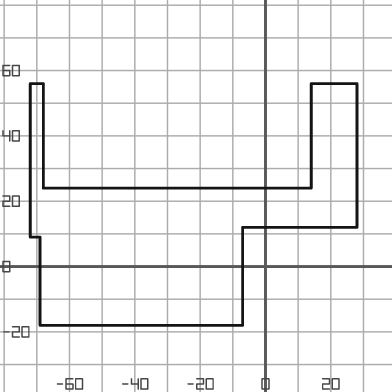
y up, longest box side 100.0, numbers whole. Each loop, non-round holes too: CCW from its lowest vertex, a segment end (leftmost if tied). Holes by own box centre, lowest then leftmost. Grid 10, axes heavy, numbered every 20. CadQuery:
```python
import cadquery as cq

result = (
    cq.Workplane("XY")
    .moveTo(-69.0, -18.0)
    .lineTo(-7.0, -18.0)
    .lineTo(-7.0, 12.0)
    .lineTo(28.0, 12.0)
    .lineTo(28.0, 56.0)
    .lineTo(14.0, 56.0)
    .lineTo(14.0, 24.0)
    .lineTo(-68.0, 24.0)
    .lineTo(-68.0, 56.0)
    .lineTo(-72.0, 56.0)
    .lineTo(-72.0, 9.0)
    .lineTo(-69.0, 9.0)
    .close()
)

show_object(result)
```